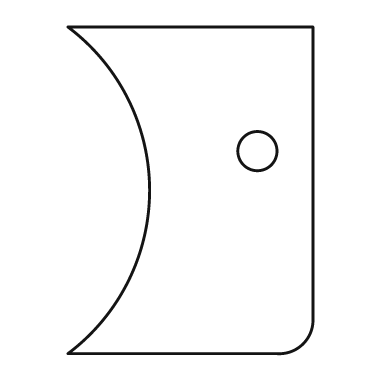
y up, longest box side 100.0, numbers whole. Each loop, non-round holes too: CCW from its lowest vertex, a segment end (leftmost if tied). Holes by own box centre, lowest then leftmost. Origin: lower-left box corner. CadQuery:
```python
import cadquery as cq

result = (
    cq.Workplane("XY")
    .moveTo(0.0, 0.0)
    .lineTo(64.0, 0.0)
    .threePointArc((72.0, 3.0), (75.0, 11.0))
    .lineTo(75.0, 100.0)
    .lineTo(0.0, 100.0)
    .threePointArc((25.0, 50.0), (0.0, 0.0))
    .close()
    .moveTo(58.0, 62.0)
    .circle(6.0)
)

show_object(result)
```